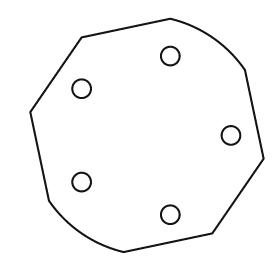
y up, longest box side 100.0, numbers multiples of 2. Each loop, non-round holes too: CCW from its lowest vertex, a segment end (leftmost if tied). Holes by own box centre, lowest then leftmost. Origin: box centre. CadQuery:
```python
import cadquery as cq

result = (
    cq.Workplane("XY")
    .moveTo(-10.0, -50.0)
    .lineTo(28.0, -42.0)
    .lineTo(50.0, -10.0)
    .lineTo(42.0, 28.0)
    .threePointArc((28.0, 42.0), (10.0, 50.0))
    .lineTo(-28.0, 42.0)
    .lineTo(-50.0, 10.0)
    .lineTo(-42.0, -28.0)
    .threePointArc((-28.0, -42.0), (-10.0, -50.0))
    .close()
    .moveTo(10.0, -34.0)
    .circle(4.0)
    .moveTo(-28.0, -20.0)
    .circle(4.0)
    .moveTo(36.0, 0.0)
    .circle(4.0)
    .moveTo(-28.0, 20.0)
    .circle(4.0)
    .moveTo(10.0, 34.0)
    .circle(4.0)
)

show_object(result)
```